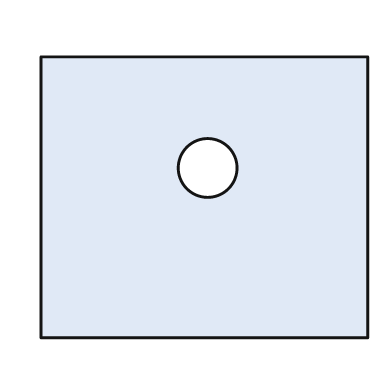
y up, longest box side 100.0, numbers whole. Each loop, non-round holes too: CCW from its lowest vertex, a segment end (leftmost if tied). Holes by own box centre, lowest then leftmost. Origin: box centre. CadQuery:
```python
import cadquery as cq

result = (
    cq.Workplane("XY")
    .moveTo(-50.0, -43.0)
    .lineTo(50.0, -43.0)
    .lineTo(50.0, 43.0)
    .lineTo(-50.0, 43.0)
    .close()
    .moveTo(1.0, 9.0)
    .circle(9.0)
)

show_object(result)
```